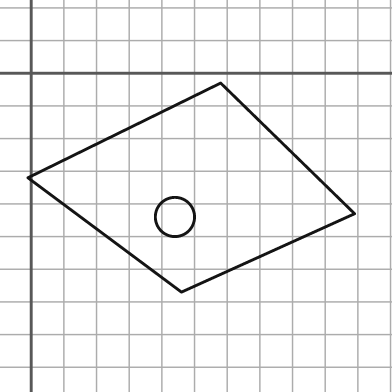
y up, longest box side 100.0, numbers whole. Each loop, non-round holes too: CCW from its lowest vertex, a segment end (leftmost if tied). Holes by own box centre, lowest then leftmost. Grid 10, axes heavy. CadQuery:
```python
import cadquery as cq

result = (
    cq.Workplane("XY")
    .moveTo(46.0, -67.0)
    .lineTo(99.0, -43.0)
    .lineTo(58.0, -3.0)
    .lineTo(-1.0, -32.0)
    .close()
    .moveTo(44.0, -44.0)
    .circle(6.0)
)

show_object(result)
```